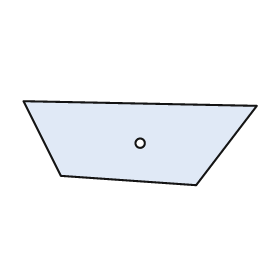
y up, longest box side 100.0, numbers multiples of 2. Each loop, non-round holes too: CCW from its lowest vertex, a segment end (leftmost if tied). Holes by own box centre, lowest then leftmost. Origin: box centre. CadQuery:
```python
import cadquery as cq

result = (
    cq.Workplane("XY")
    .moveTo(24.0, -18.0)
    .lineTo(50.0, 16.0)
    .lineTo(-50.0, 18.0)
    .lineTo(-34.0, -14.0)
    .close()
    .moveTo(0.0, 0.0)
    .circle(2.0)
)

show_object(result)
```